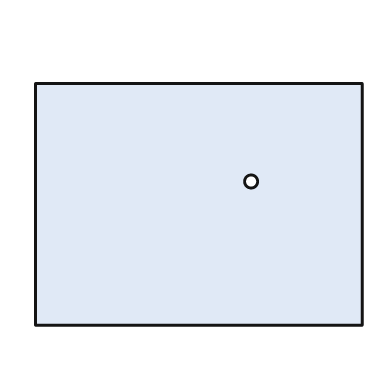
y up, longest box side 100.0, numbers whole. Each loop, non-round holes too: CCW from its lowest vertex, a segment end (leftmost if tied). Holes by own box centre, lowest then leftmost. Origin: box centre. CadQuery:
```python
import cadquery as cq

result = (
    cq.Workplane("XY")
    .moveTo(-50.0, -37.0)
    .lineTo(50.0, -37.0)
    .lineTo(50.0, 37.0)
    .lineTo(-50.0, 37.0)
    .close()
    .moveTo(16.0, 7.0)
    .circle(2.0)
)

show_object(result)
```